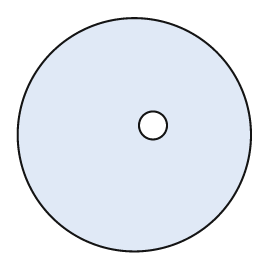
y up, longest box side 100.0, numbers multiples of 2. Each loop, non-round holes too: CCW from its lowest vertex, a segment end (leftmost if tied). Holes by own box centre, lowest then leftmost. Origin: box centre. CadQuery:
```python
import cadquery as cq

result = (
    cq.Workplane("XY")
    .moveTo(0.0, 0.0)
    .circle(50.0)
    .moveTo(8.0, 4.0)
    .circle(6.0)
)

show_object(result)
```